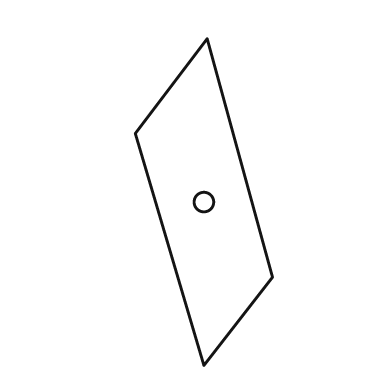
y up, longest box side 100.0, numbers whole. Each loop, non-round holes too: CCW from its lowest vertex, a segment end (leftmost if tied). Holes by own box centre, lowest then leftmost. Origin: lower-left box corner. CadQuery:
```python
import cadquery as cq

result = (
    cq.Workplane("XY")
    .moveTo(21.0, 0.0)
    .lineTo(42.0, 27.0)
    .lineTo(22.0, 100.0)
    .lineTo(0.0, 71.0)
    .close()
    .moveTo(21.0, 50.0)
    .circle(3.0)
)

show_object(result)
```